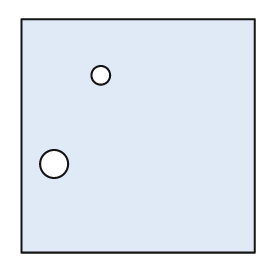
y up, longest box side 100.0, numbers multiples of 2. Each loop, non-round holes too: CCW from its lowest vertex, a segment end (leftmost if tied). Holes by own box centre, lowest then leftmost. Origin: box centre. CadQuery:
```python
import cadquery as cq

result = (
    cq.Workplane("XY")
    .moveTo(-50.0, -50.0)
    .lineTo(50.0, -50.0)
    .lineTo(50.0, 50.0)
    .lineTo(-50.0, 50.0)
    .close()
    .moveTo(-36.0, -12.0)
    .circle(6.0)
    .moveTo(-16.0, 26.0)
    .circle(4.0)
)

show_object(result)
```